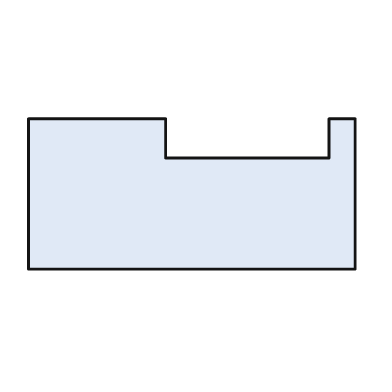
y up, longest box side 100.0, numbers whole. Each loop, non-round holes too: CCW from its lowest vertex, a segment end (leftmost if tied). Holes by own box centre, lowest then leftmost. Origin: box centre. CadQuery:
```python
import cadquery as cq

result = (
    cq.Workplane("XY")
    .moveTo(-50.0, -23.0)
    .lineTo(50.0, -23.0)
    .lineTo(50.0, 23.0)
    .lineTo(42.0, 23.0)
    .lineTo(42.0, 11.0)
    .lineTo(-8.0, 11.0)
    .lineTo(-8.0, 23.0)
    .lineTo(-50.0, 23.0)
    .close()
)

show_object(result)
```